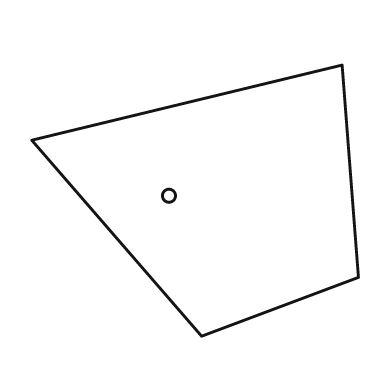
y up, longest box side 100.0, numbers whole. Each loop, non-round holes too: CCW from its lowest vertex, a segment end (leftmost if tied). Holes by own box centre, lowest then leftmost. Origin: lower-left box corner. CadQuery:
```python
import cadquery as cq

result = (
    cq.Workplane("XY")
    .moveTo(52.0, 0.0)
    .lineTo(100.0, 18.0)
    .lineTo(95.0, 83.0)
    .lineTo(0.0, 60.0)
    .close()
    .moveTo(42.0, 43.0)
    .circle(2.0)
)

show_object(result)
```